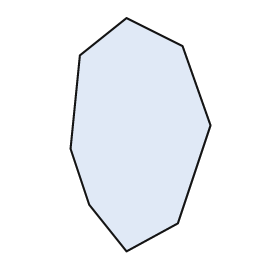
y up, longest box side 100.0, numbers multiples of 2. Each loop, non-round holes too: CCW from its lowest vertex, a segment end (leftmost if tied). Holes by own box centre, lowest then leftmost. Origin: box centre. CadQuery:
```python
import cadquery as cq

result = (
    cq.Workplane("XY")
    .moveTo(-6.0, -50.0)
    .lineTo(16.0, -38.0)
    .lineTo(30.0, 4.0)
    .lineTo(18.0, 38.0)
    .lineTo(-6.0, 50.0)
    .lineTo(-26.0, 34.0)
    .lineTo(-30.0, -6.0)
    .lineTo(-22.0, -30.0)
    .close()
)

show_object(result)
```